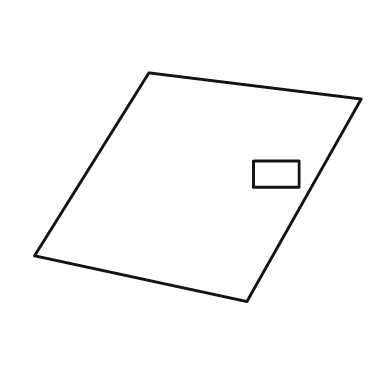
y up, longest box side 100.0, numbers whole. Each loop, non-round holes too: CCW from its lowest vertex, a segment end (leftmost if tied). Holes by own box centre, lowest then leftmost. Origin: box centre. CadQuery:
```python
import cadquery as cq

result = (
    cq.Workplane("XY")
    .moveTo(15.0, -35.0)
    .lineTo(50.0, 27.0)
    .lineTo(-15.0, 35.0)
    .lineTo(-50.0, -21.0)
    .close()
    .moveTo(17.0, 0.0)
    .lineTo(31.0, 0.0)
    .lineTo(31.0, 8.0)
    .lineTo(17.0, 8.0)
    .close()
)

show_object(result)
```